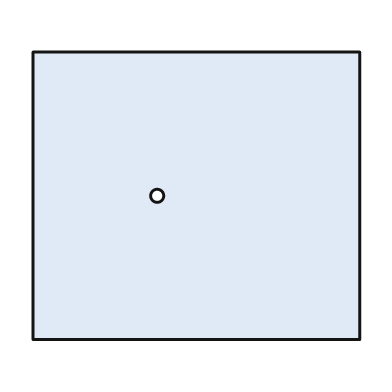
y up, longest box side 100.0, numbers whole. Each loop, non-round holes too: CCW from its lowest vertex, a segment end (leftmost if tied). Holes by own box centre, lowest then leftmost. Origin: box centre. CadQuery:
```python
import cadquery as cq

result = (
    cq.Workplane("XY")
    .moveTo(-50.0, -44.0)
    .lineTo(50.0, -44.0)
    .lineTo(50.0, 44.0)
    .lineTo(-50.0, 44.0)
    .close()
    .moveTo(-12.0, 0.0)
    .circle(2.0)
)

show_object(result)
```